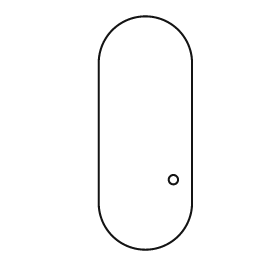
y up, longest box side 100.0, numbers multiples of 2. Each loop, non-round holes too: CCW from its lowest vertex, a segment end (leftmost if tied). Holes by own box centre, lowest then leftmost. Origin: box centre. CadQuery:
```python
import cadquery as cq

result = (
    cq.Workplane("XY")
    .moveTo(-20.0, -30.0)
    .threePointArc((0.0, -50.0), (20.0, -30.0))
    .lineTo(20.0, 30.0)
    .threePointArc((0.0, 50.0), (-20.0, 30.0))
    .close()
    .moveTo(12.0, -20.0)
    .circle(2.0)
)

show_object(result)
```